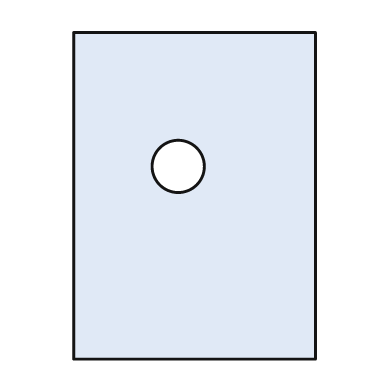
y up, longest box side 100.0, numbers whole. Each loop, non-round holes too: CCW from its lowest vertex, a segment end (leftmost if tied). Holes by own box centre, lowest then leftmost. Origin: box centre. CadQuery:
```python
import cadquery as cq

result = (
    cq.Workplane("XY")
    .moveTo(-37.0, -50.0)
    .lineTo(37.0, -50.0)
    .lineTo(37.0, 50.0)
    .lineTo(-37.0, 50.0)
    .close()
    .moveTo(-5.0, 9.0)
    .circle(8.0)
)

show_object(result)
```